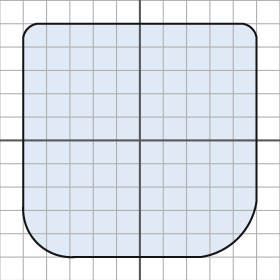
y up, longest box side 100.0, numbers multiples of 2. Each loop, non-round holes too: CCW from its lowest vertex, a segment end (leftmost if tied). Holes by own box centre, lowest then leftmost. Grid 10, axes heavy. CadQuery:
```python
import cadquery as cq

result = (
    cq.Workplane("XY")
    .moveTo(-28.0, -50.0)
    .lineTo(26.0, -50.0)
    .threePointArc((42.0, -42.0), (50.0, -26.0))
    .lineTo(50.0, 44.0)
    .threePointArc((48.0, 48.0), (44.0, 50.0))
    .lineTo(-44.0, 50.0)
    .threePointArc((-48.0, 48.0), (-50.0, 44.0))
    .lineTo(-50.0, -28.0)
    .threePointArc((-44.0, -44.0), (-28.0, -50.0))
    .close()
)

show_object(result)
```